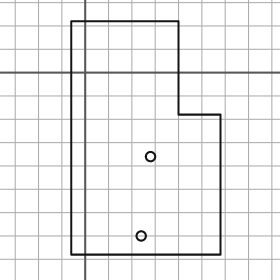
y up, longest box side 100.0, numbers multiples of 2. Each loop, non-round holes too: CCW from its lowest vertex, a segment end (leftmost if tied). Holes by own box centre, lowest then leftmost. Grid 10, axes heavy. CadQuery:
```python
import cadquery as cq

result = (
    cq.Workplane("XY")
    .moveTo(-6.0, -78.0)
    .lineTo(58.0, -78.0)
    .lineTo(58.0, -18.0)
    .lineTo(40.0, -18.0)
    .lineTo(40.0, 22.0)
    .lineTo(-6.0, 22.0)
    .close()
    .moveTo(24.0, -70.0)
    .circle(2.0)
    .moveTo(28.0, -36.0)
    .circle(2.0)
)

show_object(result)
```